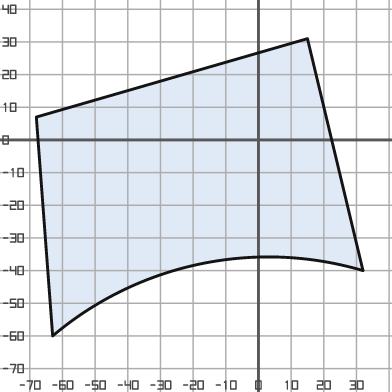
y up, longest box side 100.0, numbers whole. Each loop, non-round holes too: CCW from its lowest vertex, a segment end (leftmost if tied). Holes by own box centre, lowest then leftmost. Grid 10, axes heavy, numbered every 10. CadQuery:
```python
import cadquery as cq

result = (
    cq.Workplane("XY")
    .moveTo(-63.0, -60.0)
    .threePointArc((-18.0, -38.0), (32.0, -40.0))
    .lineTo(15.0, 31.0)
    .lineTo(-68.0, 7.0)
    .close()
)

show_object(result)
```